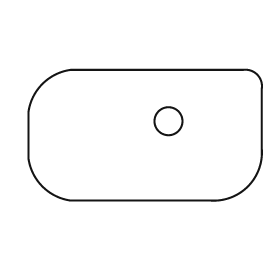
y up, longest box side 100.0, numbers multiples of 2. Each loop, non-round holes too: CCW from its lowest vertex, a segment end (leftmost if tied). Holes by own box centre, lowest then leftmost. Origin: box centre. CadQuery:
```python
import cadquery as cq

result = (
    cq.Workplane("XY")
    .moveTo(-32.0, -28.0)
    .lineTo(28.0, -28.0)
    .threePointArc((44.0, -22.0), (50.0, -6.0))
    .lineTo(50.0, 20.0)
    .threePointArc((48.0, 26.0), (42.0, 28.0))
    .lineTo(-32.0, 28.0)
    .threePointArc((-44.0, 22.0), (-50.0, 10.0))
    .lineTo(-50.0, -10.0)
    .threePointArc((-44.0, -22.0), (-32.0, -28.0))
    .close()
    .moveTo(10.0, 6.0)
    .circle(6.0)
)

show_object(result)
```